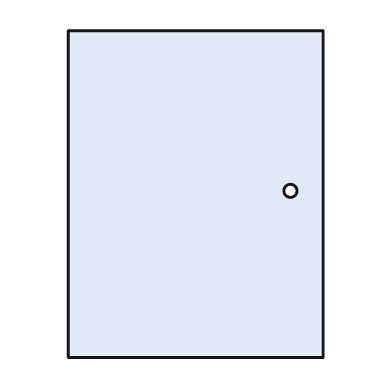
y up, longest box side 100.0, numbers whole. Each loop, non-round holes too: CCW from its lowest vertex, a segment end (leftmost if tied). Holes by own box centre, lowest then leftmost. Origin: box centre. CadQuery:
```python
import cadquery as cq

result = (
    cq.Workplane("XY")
    .moveTo(-39.0, -50.0)
    .lineTo(39.0, -50.0)
    .lineTo(39.0, 50.0)
    .lineTo(-39.0, 50.0)
    .close()
    .moveTo(29.0, 1.0)
    .circle(2.0)
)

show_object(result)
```